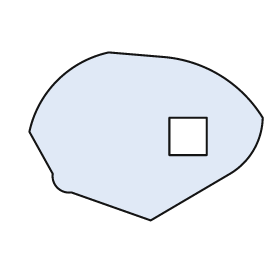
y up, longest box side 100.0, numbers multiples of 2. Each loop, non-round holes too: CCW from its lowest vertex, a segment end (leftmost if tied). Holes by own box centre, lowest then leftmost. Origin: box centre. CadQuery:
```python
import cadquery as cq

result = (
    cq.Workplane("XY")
    .moveTo(2.0, -36.0)
    .lineTo(36.0, -16.0)
    .threePointArc((46.0, -6.0), (50.0, 8.0))
    .threePointArc((32.0, 26.0), (8.0, 34.0))
    .lineTo(-16.0, 36.0)
    .threePointArc((-38.0, 24.0), (-50.0, 2.0))
    .lineTo(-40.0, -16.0)
    .threePointArc((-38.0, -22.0), (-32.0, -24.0))
    .close()
    .moveTo(10.0, -8.0)
    .lineTo(26.0, -8.0)
    .lineTo(26.0, 8.0)
    .lineTo(10.0, 8.0)
    .close()
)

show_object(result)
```